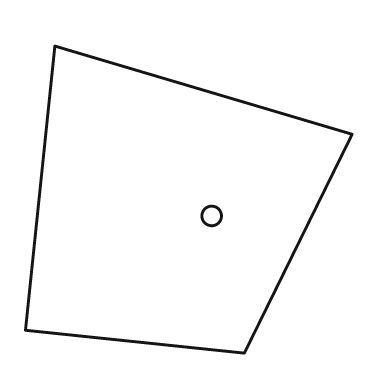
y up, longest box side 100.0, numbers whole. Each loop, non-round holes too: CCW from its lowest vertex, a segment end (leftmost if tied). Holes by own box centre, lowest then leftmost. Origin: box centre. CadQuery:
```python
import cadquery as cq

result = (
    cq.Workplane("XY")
    .moveTo(17.0, -47.0)
    .lineTo(50.0, 20.0)
    .lineTo(-41.0, 47.0)
    .lineTo(-50.0, -40.0)
    .close()
    .moveTo(7.0, -5.0)
    .circle(3.0)
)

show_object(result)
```